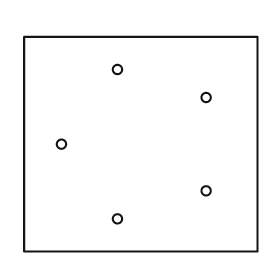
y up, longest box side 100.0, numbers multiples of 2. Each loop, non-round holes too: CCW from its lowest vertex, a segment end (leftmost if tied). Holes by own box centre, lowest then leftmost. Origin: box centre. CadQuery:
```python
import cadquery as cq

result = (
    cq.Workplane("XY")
    .moveTo(-50.0, -46.0)
    .lineTo(50.0, -46.0)
    .lineTo(50.0, 46.0)
    .lineTo(-50.0, 46.0)
    .close()
    .moveTo(-10.0, -32.0)
    .circle(2.0)
    .moveTo(28.0, -20.0)
    .circle(2.0)
    .moveTo(-34.0, 0.0)
    .circle(2.0)
    .moveTo(28.0, 20.0)
    .circle(2.0)
    .moveTo(-10.0, 32.0)
    .circle(2.0)
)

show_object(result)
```